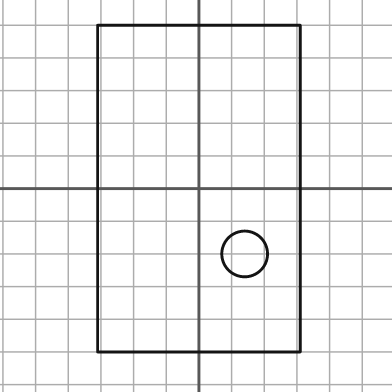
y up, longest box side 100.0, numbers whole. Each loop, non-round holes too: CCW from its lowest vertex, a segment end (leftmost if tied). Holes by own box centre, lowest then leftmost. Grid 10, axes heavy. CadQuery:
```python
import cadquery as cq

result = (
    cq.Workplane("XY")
    .moveTo(-31.0, -50.0)
    .lineTo(31.0, -50.0)
    .lineTo(31.0, 50.0)
    .lineTo(-31.0, 50.0)
    .close()
    .moveTo(14.0, -20.0)
    .circle(7.0)
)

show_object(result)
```